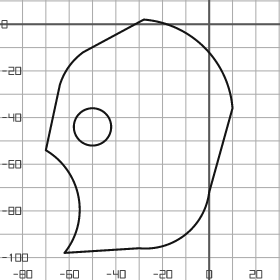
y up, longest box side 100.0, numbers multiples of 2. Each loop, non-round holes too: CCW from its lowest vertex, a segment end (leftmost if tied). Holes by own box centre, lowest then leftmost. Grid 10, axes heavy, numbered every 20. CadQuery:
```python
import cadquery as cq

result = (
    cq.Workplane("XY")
    .moveTo(-62.0, -98.0)
    .lineTo(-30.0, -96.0)
    .threePointArc((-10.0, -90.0), (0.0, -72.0))
    .lineTo(10.0, -36.0)
    .threePointArc((-2.0, -10.0), (-28.0, 2.0))
    .lineTo(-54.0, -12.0)
    .threePointArc((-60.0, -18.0), (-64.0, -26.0))
    .lineTo(-70.0, -54.0)
    .threePointArc((-56.0, -74.0), (-62.0, -98.0))
    .close()
    .moveTo(-50.0, -44.0)
    .circle(8.0)
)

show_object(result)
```